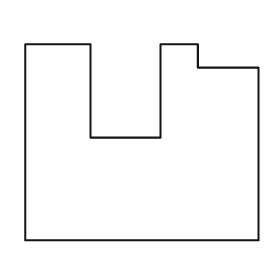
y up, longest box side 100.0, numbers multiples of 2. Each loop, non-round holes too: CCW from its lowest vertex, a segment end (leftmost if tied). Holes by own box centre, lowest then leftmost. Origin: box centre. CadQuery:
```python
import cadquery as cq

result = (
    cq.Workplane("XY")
    .moveTo(-50.0, -42.0)
    .lineTo(50.0, -42.0)
    .lineTo(50.0, 32.0)
    .lineTo(24.0, 32.0)
    .lineTo(24.0, 42.0)
    .lineTo(8.0, 42.0)
    .lineTo(8.0, 2.0)
    .lineTo(-22.0, 2.0)
    .lineTo(-22.0, 42.0)
    .lineTo(-50.0, 42.0)
    .close()
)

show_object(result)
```